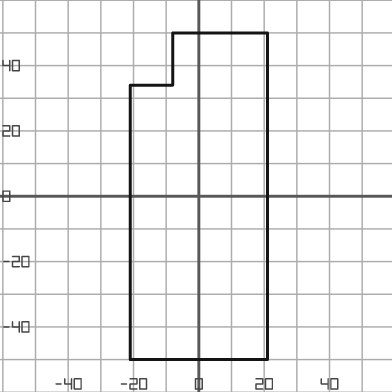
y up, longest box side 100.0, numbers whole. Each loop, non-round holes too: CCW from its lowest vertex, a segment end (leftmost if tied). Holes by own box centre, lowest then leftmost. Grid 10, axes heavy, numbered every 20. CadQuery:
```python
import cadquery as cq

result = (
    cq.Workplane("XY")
    .moveTo(-21.0, -50.0)
    .lineTo(21.0, -50.0)
    .lineTo(21.0, 50.0)
    .lineTo(-8.0, 50.0)
    .lineTo(-8.0, 34.0)
    .lineTo(-21.0, 34.0)
    .close()
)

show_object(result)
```